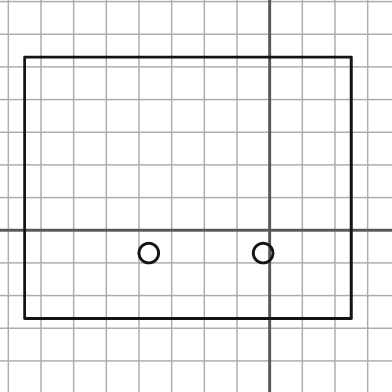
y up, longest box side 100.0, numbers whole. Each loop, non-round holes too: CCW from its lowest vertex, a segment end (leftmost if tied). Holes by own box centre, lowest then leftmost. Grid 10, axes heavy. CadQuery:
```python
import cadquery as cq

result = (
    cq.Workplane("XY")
    .moveTo(-75.0, -27.0)
    .lineTo(25.0, -27.0)
    .lineTo(25.0, 53.0)
    .lineTo(-75.0, 53.0)
    .close()
    .moveTo(-37.0, -7.0)
    .circle(3.0)
    .moveTo(-2.0, -7.0)
    .circle(3.0)
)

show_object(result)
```